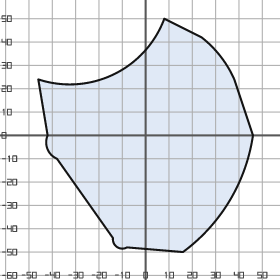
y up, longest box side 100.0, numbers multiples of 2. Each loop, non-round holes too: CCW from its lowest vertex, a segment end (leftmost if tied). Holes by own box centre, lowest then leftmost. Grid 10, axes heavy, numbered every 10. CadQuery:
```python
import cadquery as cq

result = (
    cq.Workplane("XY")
    .moveTo(16.0, -50.0)
    .threePointArc((36.0, -28.0), (46.0, 0.0))
    .lineTo(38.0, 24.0)
    .threePointArc((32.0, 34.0), (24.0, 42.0))
    .lineTo(8.0, 50.0)
    .threePointArc((-14.0, 26.0), (-46.0, 24.0))
    .lineTo(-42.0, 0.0)
    .threePointArc((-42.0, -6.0), (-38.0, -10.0))
    .lineTo(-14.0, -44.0)
    .threePointArc((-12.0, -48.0), (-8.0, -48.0))
    .close()
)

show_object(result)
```